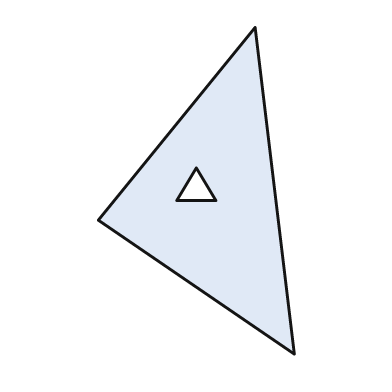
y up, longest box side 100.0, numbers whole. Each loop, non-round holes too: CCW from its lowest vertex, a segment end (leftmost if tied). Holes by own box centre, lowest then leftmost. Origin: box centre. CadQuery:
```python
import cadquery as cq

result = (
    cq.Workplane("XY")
    .moveTo(30.0, -50.0)
    .lineTo(18.0, 50.0)
    .lineTo(-30.0, -9.0)
    .close()
    .moveTo(-6.0, -3.0)
    .lineTo(6.0, -3.0)
    .lineTo(0.0, 7.0)
    .close()
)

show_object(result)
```